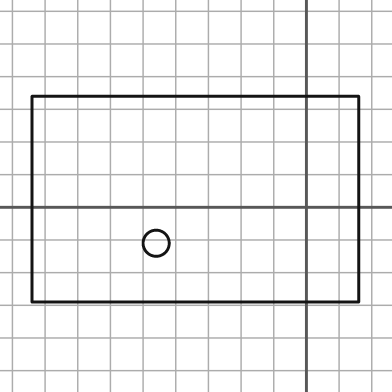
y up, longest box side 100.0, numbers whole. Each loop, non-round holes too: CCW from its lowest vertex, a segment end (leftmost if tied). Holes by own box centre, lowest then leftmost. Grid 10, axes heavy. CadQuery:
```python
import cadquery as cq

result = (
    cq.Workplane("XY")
    .moveTo(-84.0, -29.0)
    .lineTo(16.0, -29.0)
    .lineTo(16.0, 34.0)
    .lineTo(-84.0, 34.0)
    .close()
    .moveTo(-46.0, -11.0)
    .circle(4.0)
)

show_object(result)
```